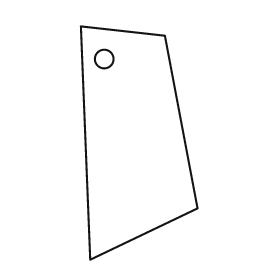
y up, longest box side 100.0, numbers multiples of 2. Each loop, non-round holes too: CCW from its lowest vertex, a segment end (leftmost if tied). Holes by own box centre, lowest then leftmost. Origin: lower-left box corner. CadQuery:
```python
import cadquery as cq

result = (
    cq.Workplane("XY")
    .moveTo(4.0, 0.0)
    .lineTo(50.0, 22.0)
    .lineTo(36.0, 96.0)
    .lineTo(0.0, 100.0)
    .close()
    .moveTo(10.0, 86.0)
    .circle(4.0)
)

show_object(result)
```